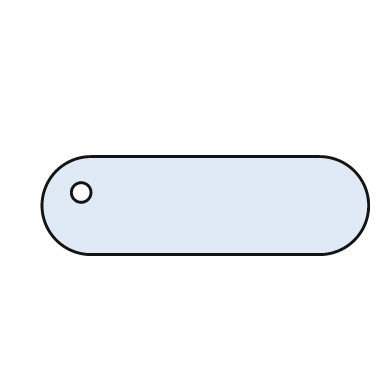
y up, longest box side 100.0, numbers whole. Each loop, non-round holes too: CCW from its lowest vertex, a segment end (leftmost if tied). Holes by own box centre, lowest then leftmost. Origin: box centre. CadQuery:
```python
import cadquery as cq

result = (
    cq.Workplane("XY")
    .moveTo(-35.0, -15.0)
    .lineTo(35.0, -15.0)
    .threePointArc((50.0, 0.0), (35.0, 15.0))
    .lineTo(-35.0, 15.0)
    .threePointArc((-50.0, 0.0), (-35.0, -15.0))
    .close()
    .moveTo(-38.0, 4.0)
    .circle(3.0)
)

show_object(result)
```